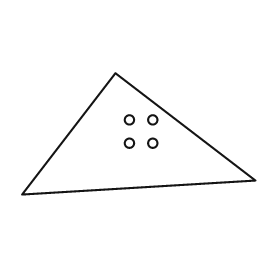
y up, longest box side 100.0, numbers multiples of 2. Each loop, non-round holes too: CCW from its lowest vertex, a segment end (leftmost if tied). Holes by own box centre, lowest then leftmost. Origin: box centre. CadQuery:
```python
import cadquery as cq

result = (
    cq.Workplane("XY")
    .moveTo(-50.0, -26.0)
    .lineTo(50.0, -20.0)
    .lineTo(-10.0, 26.0)
    .close()
    .moveTo(-4.0, -4.0)
    .circle(2.0)
    .moveTo(6.0, -4.0)
    .circle(2.0)
    .moveTo(-4.0, 6.0)
    .circle(2.0)
    .moveTo(6.0, 6.0)
    .circle(2.0)
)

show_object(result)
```